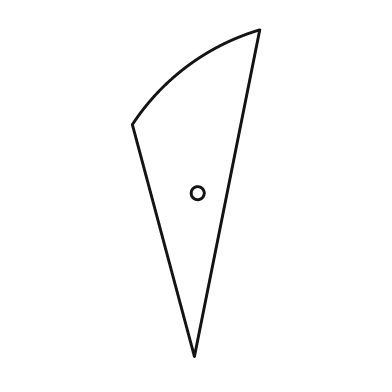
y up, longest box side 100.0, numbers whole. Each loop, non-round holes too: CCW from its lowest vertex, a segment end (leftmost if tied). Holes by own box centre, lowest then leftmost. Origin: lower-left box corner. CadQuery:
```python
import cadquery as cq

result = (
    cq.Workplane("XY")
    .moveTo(19.0, 0.0)
    .lineTo(39.0, 100.0)
    .threePointArc((17.0, 89.0), (0.0, 71.0))
    .close()
    .moveTo(20.0, 50.0)
    .circle(2.0)
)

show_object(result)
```